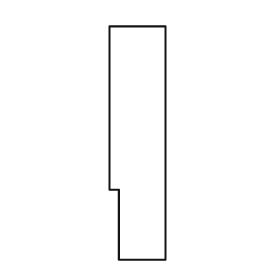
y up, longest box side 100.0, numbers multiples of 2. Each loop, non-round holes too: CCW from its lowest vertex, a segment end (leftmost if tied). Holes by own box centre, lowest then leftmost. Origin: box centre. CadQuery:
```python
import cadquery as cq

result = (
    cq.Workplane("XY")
    .moveTo(-8.0, -50.0)
    .lineTo(12.0, -50.0)
    .lineTo(12.0, 50.0)
    .lineTo(-12.0, 50.0)
    .lineTo(-12.0, -20.0)
    .lineTo(-8.0, -20.0)
    .close()
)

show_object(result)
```